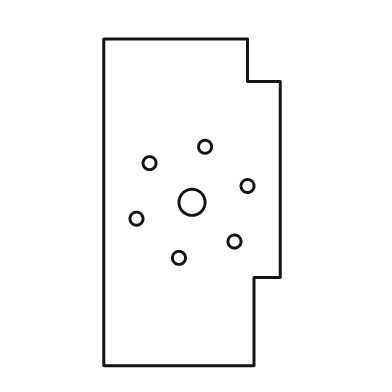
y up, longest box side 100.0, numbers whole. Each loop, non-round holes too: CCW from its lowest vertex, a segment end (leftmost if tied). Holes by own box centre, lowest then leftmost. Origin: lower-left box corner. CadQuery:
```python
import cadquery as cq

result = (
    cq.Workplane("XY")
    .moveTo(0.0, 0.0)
    .lineTo(46.0, 0.0)
    .lineTo(46.0, 27.0)
    .lineTo(54.0, 27.0)
    .lineTo(54.0, 87.0)
    .lineTo(44.0, 87.0)
    .lineTo(44.0, 100.0)
    .lineTo(0.0, 100.0)
    .close()
    .moveTo(23.0, 33.0)
    .circle(2.0)
    .moveTo(40.0, 38.0)
    .circle(2.0)
    .moveTo(10.0, 45.0)
    .circle(2.0)
    .moveTo(27.0, 50.0)
    .circle(4.0)
    .moveTo(44.0, 55.0)
    .circle(2.0)
    .moveTo(14.0, 62.0)
    .circle(2.0)
    .moveTo(31.0, 67.0)
    .circle(2.0)
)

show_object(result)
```